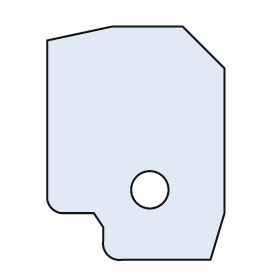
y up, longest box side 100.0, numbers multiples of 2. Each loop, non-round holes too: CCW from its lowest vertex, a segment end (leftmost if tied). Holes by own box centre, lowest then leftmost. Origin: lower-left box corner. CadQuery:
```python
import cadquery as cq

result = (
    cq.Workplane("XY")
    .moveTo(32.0, 0.0)
    .lineTo(70.0, 0.0)
    .lineTo(76.0, 20.0)
    .lineTo(76.0, 82.0)
    .lineTo(58.0, 100.0)
    .lineTo(28.0, 100.0)
    .lineTo(0.0, 94.0)
    .lineTo(0.0, 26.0)
    .threePointArc((2.0, 22.0), (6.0, 20.0))
    .lineTo(20.0, 20.0)
    .lineTo(24.0, 14.0)
    .lineTo(24.0, 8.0)
    .threePointArc((26.0, 2.0), (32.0, 0.0))
    .close()
    .moveTo(44.0, 30.0)
    .circle(8.0)
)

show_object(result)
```